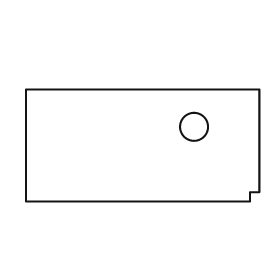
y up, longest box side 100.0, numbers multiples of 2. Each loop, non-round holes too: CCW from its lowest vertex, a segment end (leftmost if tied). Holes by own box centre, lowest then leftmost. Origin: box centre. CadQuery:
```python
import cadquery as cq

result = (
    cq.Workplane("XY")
    .moveTo(-50.0, -24.0)
    .lineTo(46.0, -24.0)
    .lineTo(46.0, -20.0)
    .lineTo(50.0, -20.0)
    .lineTo(50.0, 24.0)
    .lineTo(-50.0, 24.0)
    .close()
    .moveTo(22.0, 8.0)
    .circle(6.0)
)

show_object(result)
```